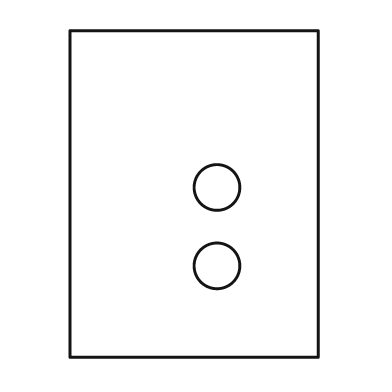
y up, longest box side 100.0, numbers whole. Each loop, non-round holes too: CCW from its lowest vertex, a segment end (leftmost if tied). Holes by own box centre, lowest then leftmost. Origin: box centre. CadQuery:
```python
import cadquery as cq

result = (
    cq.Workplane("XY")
    .moveTo(-38.0, -50.0)
    .lineTo(38.0, -50.0)
    .lineTo(38.0, 50.0)
    .lineTo(-38.0, 50.0)
    .close()
    .moveTo(7.0, -22.0)
    .circle(7.0)
    .moveTo(7.0, 2.0)
    .circle(7.0)
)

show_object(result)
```